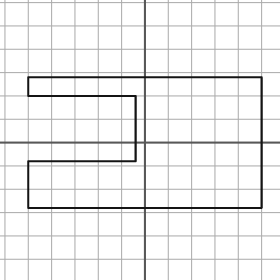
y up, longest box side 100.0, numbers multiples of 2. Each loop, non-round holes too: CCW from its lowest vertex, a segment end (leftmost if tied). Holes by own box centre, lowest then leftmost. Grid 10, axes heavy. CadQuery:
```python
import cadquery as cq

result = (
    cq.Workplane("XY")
    .moveTo(-50.0, -28.0)
    .lineTo(50.0, -28.0)
    .lineTo(50.0, 28.0)
    .lineTo(-50.0, 28.0)
    .lineTo(-50.0, 20.0)
    .lineTo(-4.0, 20.0)
    .lineTo(-4.0, -8.0)
    .lineTo(-50.0, -8.0)
    .close()
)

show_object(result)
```